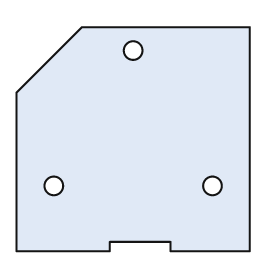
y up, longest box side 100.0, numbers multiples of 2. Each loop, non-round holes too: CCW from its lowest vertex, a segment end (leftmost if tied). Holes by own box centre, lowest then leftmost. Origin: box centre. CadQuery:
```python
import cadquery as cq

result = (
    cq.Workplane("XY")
    .moveTo(-50.0, -48.0)
    .lineTo(-10.0, -48.0)
    .lineTo(-10.0, -44.0)
    .lineTo(16.0, -44.0)
    .lineTo(16.0, -48.0)
    .lineTo(50.0, -48.0)
    .lineTo(50.0, 48.0)
    .lineTo(-22.0, 48.0)
    .lineTo(-50.0, 20.0)
    .close()
    .moveTo(-34.0, -20.0)
    .circle(4.0)
    .moveTo(34.0, -20.0)
    .circle(4.0)
    .moveTo(0.0, 38.0)
    .circle(4.0)
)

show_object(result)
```